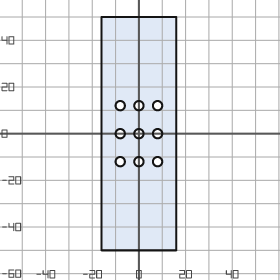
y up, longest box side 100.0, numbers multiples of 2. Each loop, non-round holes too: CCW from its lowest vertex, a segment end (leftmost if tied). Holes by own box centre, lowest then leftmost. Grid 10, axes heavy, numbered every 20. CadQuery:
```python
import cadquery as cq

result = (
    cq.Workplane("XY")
    .moveTo(-16.0, -50.0)
    .lineTo(16.0, -50.0)
    .lineTo(16.0, 50.0)
    .lineTo(-16.0, 50.0)
    .close()
    .moveTo(-8.0, -12.0)
    .circle(2.0)
    .moveTo(0.0, -12.0)
    .circle(2.0)
    .moveTo(8.0, -12.0)
    .circle(2.0)
    .moveTo(-8.0, 0.0)
    .circle(2.0)
    .moveTo(0.0, 0.0)
    .circle(2.0)
    .moveTo(8.0, 0.0)
    .circle(2.0)
    .moveTo(-8.0, 12.0)
    .circle(2.0)
    .moveTo(0.0, 12.0)
    .circle(2.0)
    .moveTo(8.0, 12.0)
    .circle(2.0)
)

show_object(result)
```